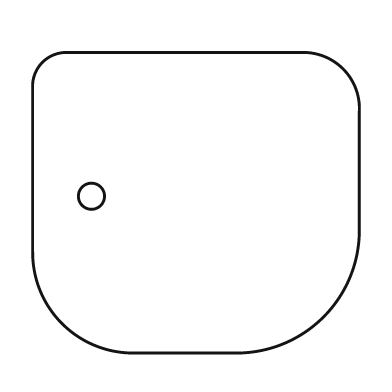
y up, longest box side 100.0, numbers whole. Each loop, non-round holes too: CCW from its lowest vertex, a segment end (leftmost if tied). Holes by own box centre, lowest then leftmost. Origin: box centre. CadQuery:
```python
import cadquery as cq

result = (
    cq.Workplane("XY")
    .moveTo(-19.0, -46.0)
    .lineTo(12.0, -46.0)
    .threePointArc((39.0, -35.0), (50.0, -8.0))
    .lineTo(50.0, 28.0)
    .threePointArc((45.0, 41.0), (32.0, 46.0))
    .lineTo(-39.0, 46.0)
    .threePointArc((-47.0, 43.0), (-50.0, 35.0))
    .lineTo(-50.0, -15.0)
    .threePointArc((-41.0, -37.0), (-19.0, -46.0))
    .close()
    .moveTo(-32.0, 2.0)
    .circle(4.0)
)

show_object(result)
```